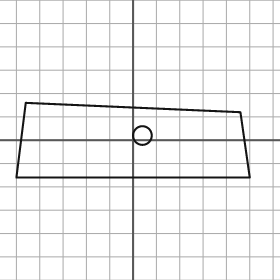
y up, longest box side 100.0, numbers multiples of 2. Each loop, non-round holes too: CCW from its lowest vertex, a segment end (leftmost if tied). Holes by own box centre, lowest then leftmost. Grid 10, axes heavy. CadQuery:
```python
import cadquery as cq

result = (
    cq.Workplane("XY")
    .moveTo(-50.0, -16.0)
    .lineTo(50.0, -16.0)
    .lineTo(46.0, 12.0)
    .lineTo(-46.0, 16.0)
    .close()
    .moveTo(4.0, 2.0)
    .circle(4.0)
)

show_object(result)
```